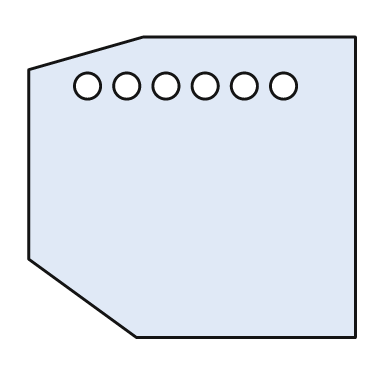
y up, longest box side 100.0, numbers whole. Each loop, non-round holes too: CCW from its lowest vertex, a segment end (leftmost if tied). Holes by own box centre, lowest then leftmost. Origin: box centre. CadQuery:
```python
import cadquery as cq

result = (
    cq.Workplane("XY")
    .moveTo(-17.0, -46.0)
    .lineTo(50.0, -46.0)
    .lineTo(50.0, 46.0)
    .lineTo(-15.0, 46.0)
    .lineTo(-50.0, 36.0)
    .lineTo(-50.0, -22.0)
    .close()
    .moveTo(-32.0, 31.0)
    .circle(4.0)
    .moveTo(-20.0, 31.0)
    .circle(4.0)
    .moveTo(-8.0, 31.0)
    .circle(4.0)
    .moveTo(4.0, 31.0)
    .circle(4.0)
    .moveTo(16.0, 31.0)
    .circle(4.0)
    .moveTo(28.0, 31.0)
    .circle(4.0)
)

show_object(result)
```